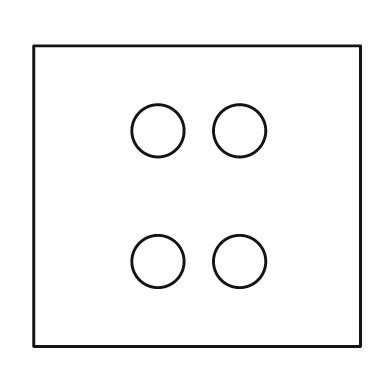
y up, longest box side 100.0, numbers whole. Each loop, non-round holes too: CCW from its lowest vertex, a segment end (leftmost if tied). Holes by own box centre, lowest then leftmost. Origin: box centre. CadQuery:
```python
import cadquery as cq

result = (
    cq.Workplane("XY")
    .moveTo(-50.0, -46.0)
    .lineTo(50.0, -46.0)
    .lineTo(50.0, 46.0)
    .lineTo(-50.0, 46.0)
    .close()
    .moveTo(-12.0, -20.0)
    .circle(8.0)
    .moveTo(13.0, -20.0)
    .circle(8.0)
    .moveTo(-12.0, 20.0)
    .circle(8.0)
    .moveTo(13.0, 20.0)
    .circle(8.0)
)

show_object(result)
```